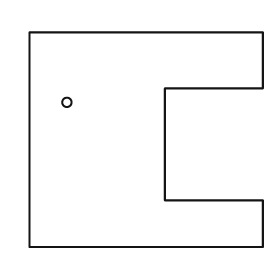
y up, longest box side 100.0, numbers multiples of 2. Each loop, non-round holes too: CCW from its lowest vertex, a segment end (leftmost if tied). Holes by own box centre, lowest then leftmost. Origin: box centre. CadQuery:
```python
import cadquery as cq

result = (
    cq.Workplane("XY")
    .moveTo(-50.0, -46.0)
    .lineTo(50.0, -46.0)
    .lineTo(50.0, -26.0)
    .lineTo(8.0, -26.0)
    .lineTo(8.0, 22.0)
    .lineTo(50.0, 22.0)
    .lineTo(50.0, 46.0)
    .lineTo(-50.0, 46.0)
    .close()
    .moveTo(-34.0, 16.0)
    .circle(2.0)
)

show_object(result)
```